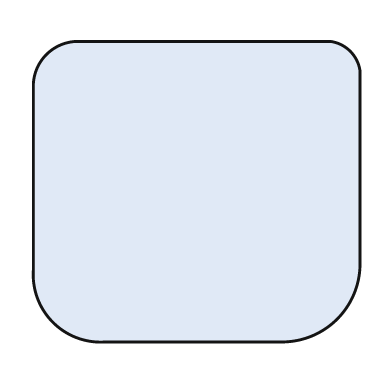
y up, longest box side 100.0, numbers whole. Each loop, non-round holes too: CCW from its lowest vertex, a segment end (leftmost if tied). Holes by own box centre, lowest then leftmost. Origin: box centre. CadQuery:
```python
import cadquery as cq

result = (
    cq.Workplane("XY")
    .moveTo(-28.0, -46.0)
    .lineTo(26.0, -46.0)
    .threePointArc((43.0, -39.0), (50.0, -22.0))
    .lineTo(50.0, 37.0)
    .threePointArc((47.0, 43.0), (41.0, 46.0))
    .lineTo(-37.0, 46.0)
    .threePointArc((-46.0, 42.0), (-50.0, 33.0))
    .lineTo(-50.0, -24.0)
    .threePointArc((-44.0, -40.0), (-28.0, -46.0))
    .close()
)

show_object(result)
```